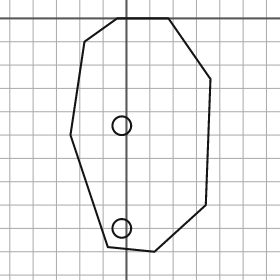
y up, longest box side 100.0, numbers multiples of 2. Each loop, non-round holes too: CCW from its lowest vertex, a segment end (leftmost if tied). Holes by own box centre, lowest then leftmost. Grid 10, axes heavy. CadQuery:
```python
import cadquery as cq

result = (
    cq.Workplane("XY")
    .moveTo(12.0, -100.0)
    .lineTo(34.0, -80.0)
    .lineTo(36.0, -26.0)
    .lineTo(18.0, 0.0)
    .lineTo(-4.0, 0.0)
    .lineTo(-18.0, -10.0)
    .lineTo(-24.0, -50.0)
    .lineTo(-8.0, -98.0)
    .close()
    .moveTo(-2.0, -90.0)
    .circle(4.0)
    .moveTo(-2.0, -46.0)
    .circle(4.0)
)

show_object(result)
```